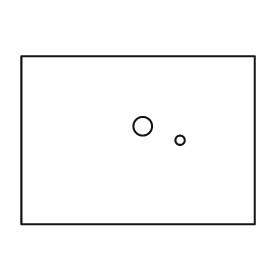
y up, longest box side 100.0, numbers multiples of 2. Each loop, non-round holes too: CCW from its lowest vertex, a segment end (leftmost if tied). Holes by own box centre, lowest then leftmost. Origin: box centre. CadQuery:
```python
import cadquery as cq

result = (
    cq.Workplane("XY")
    .moveTo(-50.0, -36.0)
    .lineTo(50.0, -36.0)
    .lineTo(50.0, 36.0)
    .lineTo(-50.0, 36.0)
    .close()
    .moveTo(18.0, 0.0)
    .circle(2.0)
    .moveTo(2.0, 6.0)
    .circle(4.0)
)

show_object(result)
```